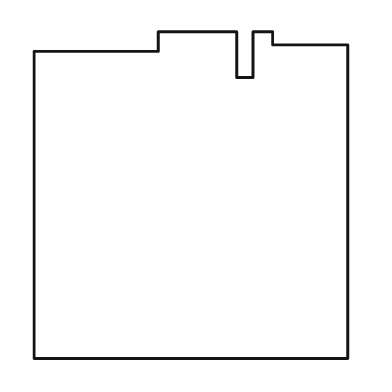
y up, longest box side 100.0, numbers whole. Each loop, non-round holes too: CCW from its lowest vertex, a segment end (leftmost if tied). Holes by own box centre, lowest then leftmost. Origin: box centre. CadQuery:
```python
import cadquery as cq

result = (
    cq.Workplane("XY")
    .moveTo(-48.0, -50.0)
    .lineTo(48.0, -50.0)
    .lineTo(48.0, 46.0)
    .lineTo(25.0, 46.0)
    .lineTo(25.0, 50.0)
    .lineTo(19.0, 50.0)
    .lineTo(19.0, 36.0)
    .lineTo(14.0, 36.0)
    .lineTo(14.0, 50.0)
    .lineTo(-10.0, 50.0)
    .lineTo(-10.0, 44.0)
    .lineTo(-48.0, 44.0)
    .close()
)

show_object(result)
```